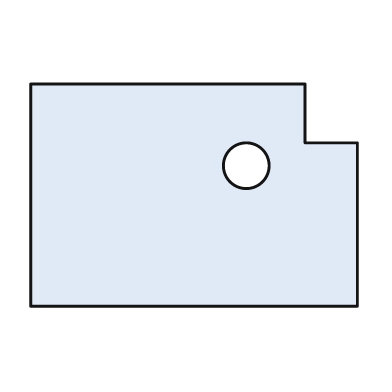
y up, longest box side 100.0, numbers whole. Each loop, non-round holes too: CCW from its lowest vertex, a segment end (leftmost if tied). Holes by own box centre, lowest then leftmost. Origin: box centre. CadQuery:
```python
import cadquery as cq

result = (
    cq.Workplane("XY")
    .moveTo(-50.0, -34.0)
    .lineTo(50.0, -34.0)
    .lineTo(50.0, 16.0)
    .lineTo(34.0, 16.0)
    .lineTo(34.0, 34.0)
    .lineTo(-50.0, 34.0)
    .close()
    .moveTo(16.0, 9.0)
    .circle(7.0)
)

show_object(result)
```